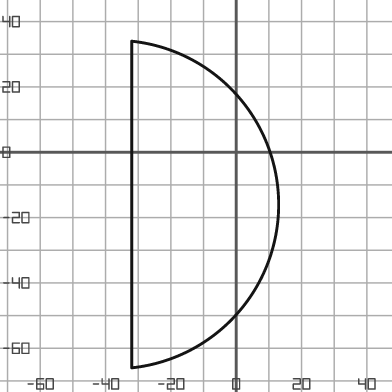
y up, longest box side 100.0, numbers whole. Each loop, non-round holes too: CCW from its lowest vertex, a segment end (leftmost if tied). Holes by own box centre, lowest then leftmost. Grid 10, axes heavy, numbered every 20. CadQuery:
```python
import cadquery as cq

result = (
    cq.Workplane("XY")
    .moveTo(-32.0, -66.0)
    .threePointArc((13.0, -16.0), (-32.0, 34.0))
    .close()
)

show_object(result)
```